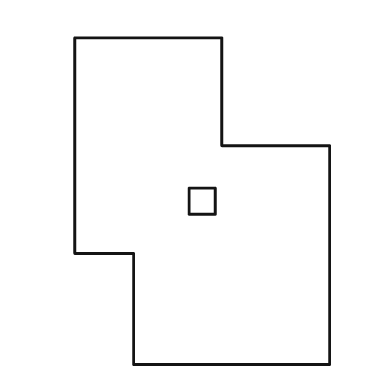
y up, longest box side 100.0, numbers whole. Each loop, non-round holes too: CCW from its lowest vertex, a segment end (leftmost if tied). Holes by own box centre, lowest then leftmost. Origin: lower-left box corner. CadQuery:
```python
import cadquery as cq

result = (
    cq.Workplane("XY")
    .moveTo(18.0, 0.0)
    .lineTo(78.0, 0.0)
    .lineTo(78.0, 67.0)
    .lineTo(45.0, 67.0)
    .lineTo(45.0, 100.0)
    .lineTo(0.0, 100.0)
    .lineTo(0.0, 34.0)
    .lineTo(18.0, 34.0)
    .close()
    .moveTo(35.0, 46.0)
    .lineTo(43.0, 46.0)
    .lineTo(43.0, 54.0)
    .lineTo(35.0, 54.0)
    .close()
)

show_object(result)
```